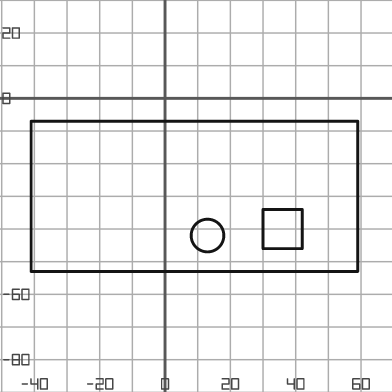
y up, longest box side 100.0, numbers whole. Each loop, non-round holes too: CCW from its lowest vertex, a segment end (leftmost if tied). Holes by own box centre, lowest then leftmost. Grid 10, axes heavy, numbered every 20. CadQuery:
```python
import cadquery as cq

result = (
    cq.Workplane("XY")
    .moveTo(-41.0, -53.0)
    .lineTo(59.0, -53.0)
    .lineTo(59.0, -7.0)
    .lineTo(-41.0, -7.0)
    .close()
    .moveTo(13.0, -42.0)
    .circle(5.0)
    .moveTo(30.0, -46.0)
    .lineTo(42.0, -46.0)
    .lineTo(42.0, -34.0)
    .lineTo(30.0, -34.0)
    .close()
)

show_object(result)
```